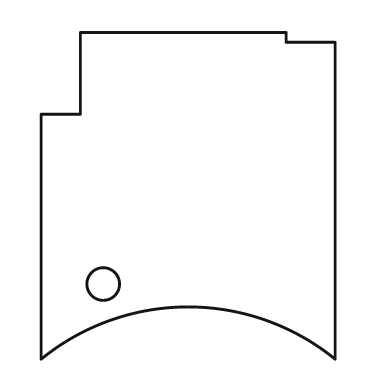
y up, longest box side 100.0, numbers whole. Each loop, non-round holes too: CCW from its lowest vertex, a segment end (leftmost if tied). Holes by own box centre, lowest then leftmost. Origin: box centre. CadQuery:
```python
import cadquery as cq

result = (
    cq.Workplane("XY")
    .moveTo(-45.0, -50.0)
    .threePointArc((0.0, -34.0), (45.0, -50.0))
    .lineTo(45.0, 47.0)
    .lineTo(30.0, 47.0)
    .lineTo(30.0, 50.0)
    .lineTo(-33.0, 50.0)
    .lineTo(-33.0, 25.0)
    .lineTo(-45.0, 25.0)
    .close()
    .moveTo(-26.0, -27.0)
    .circle(5.0)
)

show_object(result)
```